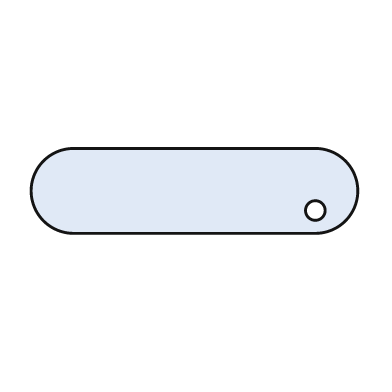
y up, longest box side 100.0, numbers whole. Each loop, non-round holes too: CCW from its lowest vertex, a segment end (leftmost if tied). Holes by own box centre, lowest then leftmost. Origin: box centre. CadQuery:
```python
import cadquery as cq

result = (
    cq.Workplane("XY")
    .moveTo(-37.0, -13.0)
    .lineTo(37.0, -13.0)
    .threePointArc((50.0, 0.0), (37.0, 13.0))
    .lineTo(-37.0, 13.0)
    .threePointArc((-50.0, 0.0), (-37.0, -13.0))
    .close()
    .moveTo(37.0, -6.0)
    .circle(3.0)
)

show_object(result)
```